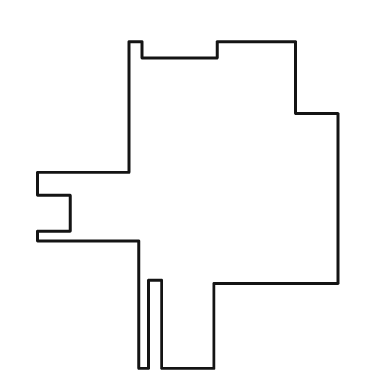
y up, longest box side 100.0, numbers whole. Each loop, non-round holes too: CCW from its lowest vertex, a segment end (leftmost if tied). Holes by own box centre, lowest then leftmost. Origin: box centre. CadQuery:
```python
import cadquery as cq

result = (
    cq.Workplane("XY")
    .moveTo(-15.0, -50.0)
    .lineTo(-12.0, -50.0)
    .lineTo(-12.0, -23.0)
    .lineTo(-8.0, -23.0)
    .lineTo(-8.0, -50.0)
    .lineTo(8.0, -50.0)
    .lineTo(8.0, -24.0)
    .lineTo(46.0, -24.0)
    .lineTo(46.0, 28.0)
    .lineTo(33.0, 28.0)
    .lineTo(33.0, 50.0)
    .lineTo(9.0, 50.0)
    .lineTo(9.0, 45.0)
    .lineTo(-14.0, 45.0)
    .lineTo(-14.0, 50.0)
    .lineTo(-18.0, 50.0)
    .lineTo(-18.0, 10.0)
    .lineTo(-46.0, 10.0)
    .lineTo(-46.0, 3.0)
    .lineTo(-36.0, 3.0)
    .lineTo(-36.0, -8.0)
    .lineTo(-46.0, -8.0)
    .lineTo(-46.0, -11.0)
    .lineTo(-15.0, -11.0)
    .close()
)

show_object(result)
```